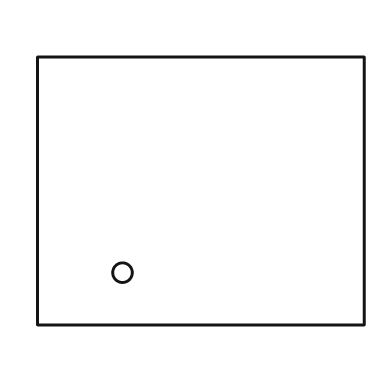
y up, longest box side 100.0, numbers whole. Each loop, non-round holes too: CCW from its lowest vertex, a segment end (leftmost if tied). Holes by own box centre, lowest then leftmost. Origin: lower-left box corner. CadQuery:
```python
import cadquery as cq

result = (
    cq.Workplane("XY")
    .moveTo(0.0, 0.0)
    .lineTo(100.0, 0.0)
    .lineTo(100.0, 82.0)
    .lineTo(0.0, 82.0)
    .close()
    .moveTo(26.0, 16.0)
    .circle(3.0)
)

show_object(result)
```